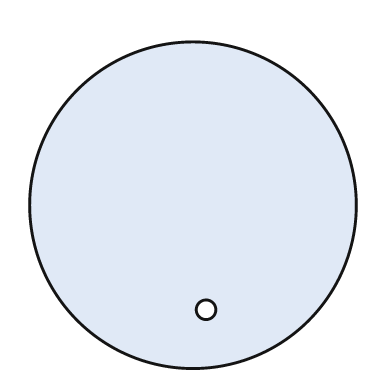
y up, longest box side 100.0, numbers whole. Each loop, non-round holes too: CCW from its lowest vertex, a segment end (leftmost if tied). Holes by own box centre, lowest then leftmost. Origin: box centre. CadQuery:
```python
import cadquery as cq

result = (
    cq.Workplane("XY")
    .moveTo(0.0, 0.0)
    .circle(50.0)
    .moveTo(4.0, -32.0)
    .circle(3.0)
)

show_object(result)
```